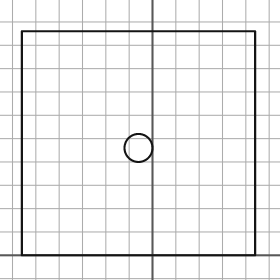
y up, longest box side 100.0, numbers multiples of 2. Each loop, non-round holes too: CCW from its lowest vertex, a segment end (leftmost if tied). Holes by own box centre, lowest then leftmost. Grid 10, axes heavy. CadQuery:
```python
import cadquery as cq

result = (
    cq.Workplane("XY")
    .moveTo(-56.0, 0.0)
    .lineTo(44.0, 0.0)
    .lineTo(44.0, 96.0)
    .lineTo(-56.0, 96.0)
    .close()
    .moveTo(-6.0, 46.0)
    .circle(6.0)
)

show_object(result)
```